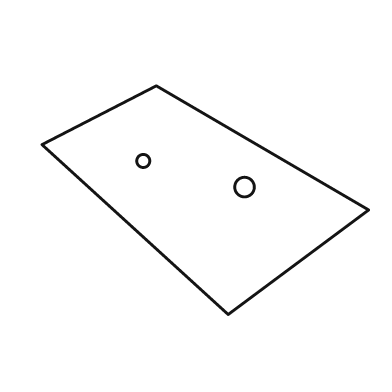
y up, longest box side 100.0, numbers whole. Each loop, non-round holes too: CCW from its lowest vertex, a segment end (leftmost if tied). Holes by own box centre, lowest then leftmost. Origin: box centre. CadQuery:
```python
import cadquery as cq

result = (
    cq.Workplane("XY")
    .moveTo(7.0, -35.0)
    .lineTo(50.0, -3.0)
    .lineTo(-15.0, 35.0)
    .lineTo(-50.0, 17.0)
    .close()
    .moveTo(12.0, 4.0)
    .circle(3.0)
    .moveTo(-19.0, 12.0)
    .circle(2.0)
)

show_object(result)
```